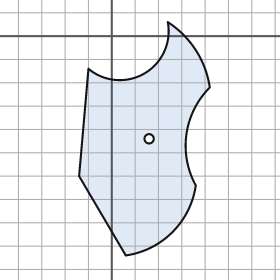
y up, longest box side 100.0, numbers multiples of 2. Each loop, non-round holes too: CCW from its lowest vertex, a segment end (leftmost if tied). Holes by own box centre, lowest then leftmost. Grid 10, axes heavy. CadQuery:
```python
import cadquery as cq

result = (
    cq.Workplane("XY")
    .moveTo(6.0, -94.0)
    .threePointArc((26.0, -84.0), (36.0, -64.0))
    .threePointArc((32.0, -42.0), (42.0, -22.0))
    .threePointArc((36.0, -6.0), (24.0, 6.0))
    .threePointArc((14.0, -16.0), (-10.0, -14.0))
    .lineTo(-14.0, -60.0)
    .close()
    .moveTo(16.0, -44.0)
    .circle(2.0)
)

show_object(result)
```